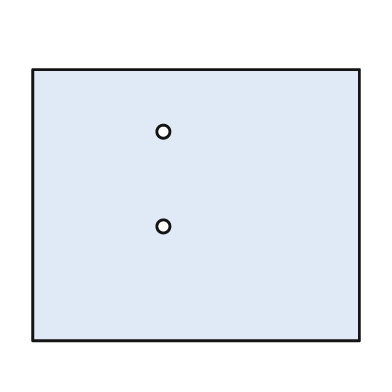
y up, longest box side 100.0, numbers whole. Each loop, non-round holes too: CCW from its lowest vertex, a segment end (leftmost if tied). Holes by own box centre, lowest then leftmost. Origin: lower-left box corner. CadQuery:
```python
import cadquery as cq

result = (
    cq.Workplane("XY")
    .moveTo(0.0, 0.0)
    .lineTo(100.0, 0.0)
    .lineTo(100.0, 83.0)
    .lineTo(0.0, 83.0)
    .close()
    .moveTo(40.0, 35.0)
    .circle(2.0)
    .moveTo(40.0, 64.0)
    .circle(2.0)
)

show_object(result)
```